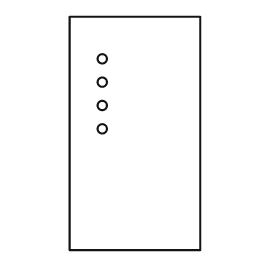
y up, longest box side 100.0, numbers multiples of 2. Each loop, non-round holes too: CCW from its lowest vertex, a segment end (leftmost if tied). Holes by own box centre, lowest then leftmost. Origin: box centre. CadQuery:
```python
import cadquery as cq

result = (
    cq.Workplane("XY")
    .moveTo(-28.0, -50.0)
    .lineTo(28.0, -50.0)
    .lineTo(28.0, 50.0)
    .lineTo(-28.0, 50.0)
    .close()
    .moveTo(-14.0, 2.0)
    .circle(2.0)
    .moveTo(-14.0, 12.0)
    .circle(2.0)
    .moveTo(-14.0, 22.0)
    .circle(2.0)
    .moveTo(-14.0, 32.0)
    .circle(2.0)
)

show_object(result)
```